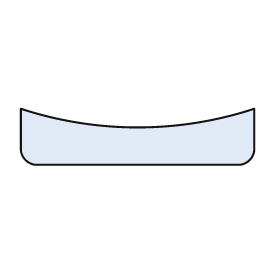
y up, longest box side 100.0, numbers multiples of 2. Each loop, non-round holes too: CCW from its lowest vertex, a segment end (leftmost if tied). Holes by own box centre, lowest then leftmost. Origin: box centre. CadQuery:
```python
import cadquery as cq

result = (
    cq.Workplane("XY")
    .moveTo(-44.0, -12.0)
    .lineTo(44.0, -12.0)
    .threePointArc((48.0, -10.0), (50.0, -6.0))
    .lineTo(50.0, 12.0)
    .threePointArc((0.0, 4.0), (-50.0, 12.0))
    .lineTo(-50.0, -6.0)
    .threePointArc((-48.0, -10.0), (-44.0, -12.0))
    .close()
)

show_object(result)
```